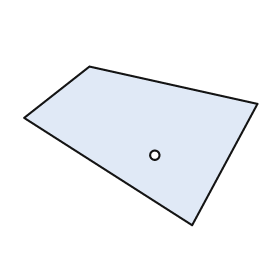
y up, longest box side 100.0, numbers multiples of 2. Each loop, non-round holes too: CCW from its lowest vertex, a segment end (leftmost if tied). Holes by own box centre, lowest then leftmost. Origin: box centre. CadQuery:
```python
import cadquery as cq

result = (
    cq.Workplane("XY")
    .moveTo(22.0, -34.0)
    .lineTo(50.0, 18.0)
    .lineTo(-22.0, 34.0)
    .lineTo(-50.0, 12.0)
    .close()
    .moveTo(6.0, -4.0)
    .circle(2.0)
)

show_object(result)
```